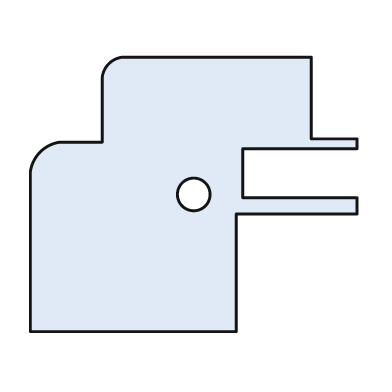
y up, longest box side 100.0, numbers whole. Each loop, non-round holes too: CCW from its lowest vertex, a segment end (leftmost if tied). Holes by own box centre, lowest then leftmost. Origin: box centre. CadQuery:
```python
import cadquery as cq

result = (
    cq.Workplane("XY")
    .moveTo(-50.0, -42.0)
    .lineTo(13.0, -42.0)
    .lineTo(13.0, -6.0)
    .lineTo(50.0, -6.0)
    .lineTo(50.0, -1.0)
    .lineTo(15.0, -1.0)
    .lineTo(15.0, 14.0)
    .lineTo(50.0, 14.0)
    .lineTo(50.0, 17.0)
    .lineTo(36.0, 17.0)
    .lineTo(36.0, 42.0)
    .lineTo(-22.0, 42.0)
    .threePointArc((-26.0, 40.0), (-28.0, 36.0))
    .lineTo(-28.0, 16.0)
    .lineTo(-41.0, 16.0)
    .threePointArc((-47.0, 13.0), (-50.0, 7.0))
    .close()
    .moveTo(0.0, 0.0)
    .circle(5.0)
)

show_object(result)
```